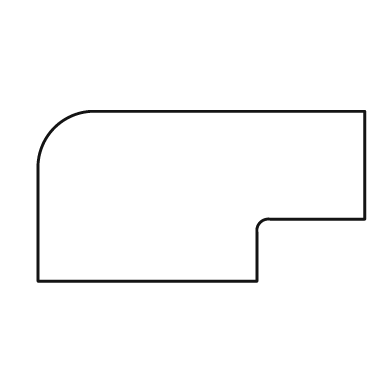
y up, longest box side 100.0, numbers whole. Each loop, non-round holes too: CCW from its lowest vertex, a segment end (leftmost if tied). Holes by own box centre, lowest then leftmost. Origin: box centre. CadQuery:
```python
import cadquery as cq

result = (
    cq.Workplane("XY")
    .moveTo(-50.0, -26.0)
    .lineTo(17.0, -26.0)
    .lineTo(17.0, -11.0)
    .threePointArc((18.0, -8.0), (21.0, -7.0))
    .lineTo(50.0, -7.0)
    .lineTo(50.0, 26.0)
    .lineTo(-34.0, 26.0)
    .threePointArc((-45.0, 21.0), (-50.0, 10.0))
    .close()
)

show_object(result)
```